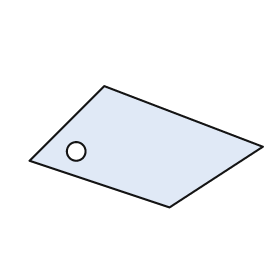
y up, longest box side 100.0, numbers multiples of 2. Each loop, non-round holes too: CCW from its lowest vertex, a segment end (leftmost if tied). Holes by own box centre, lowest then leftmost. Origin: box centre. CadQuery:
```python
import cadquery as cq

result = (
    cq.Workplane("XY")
    .moveTo(10.0, -26.0)
    .lineTo(50.0, 0.0)
    .lineTo(-18.0, 26.0)
    .lineTo(-50.0, -6.0)
    .close()
    .moveTo(-30.0, -2.0)
    .circle(4.0)
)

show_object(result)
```